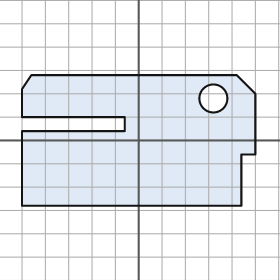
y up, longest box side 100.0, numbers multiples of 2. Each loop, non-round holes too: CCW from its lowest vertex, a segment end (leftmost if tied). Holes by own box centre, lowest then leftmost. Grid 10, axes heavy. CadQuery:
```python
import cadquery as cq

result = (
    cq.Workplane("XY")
    .moveTo(-50.0, -28.0)
    .lineTo(44.0, -28.0)
    .lineTo(44.0, -6.0)
    .lineTo(50.0, -6.0)
    .lineTo(50.0, 20.0)
    .lineTo(42.0, 28.0)
    .lineTo(-46.0, 28.0)
    .lineTo(-50.0, 22.0)
    .lineTo(-50.0, 10.0)
    .lineTo(-6.0, 10.0)
    .lineTo(-6.0, 4.0)
    .lineTo(-50.0, 4.0)
    .close()
    .moveTo(32.0, 18.0)
    .circle(6.0)
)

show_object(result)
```